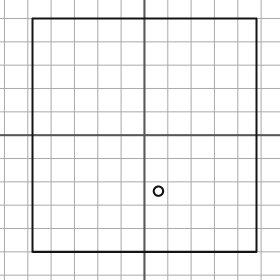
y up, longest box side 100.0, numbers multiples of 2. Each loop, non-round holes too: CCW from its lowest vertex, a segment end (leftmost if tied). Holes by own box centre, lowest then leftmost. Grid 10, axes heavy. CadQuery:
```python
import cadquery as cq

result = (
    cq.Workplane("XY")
    .moveTo(-48.0, -50.0)
    .lineTo(48.0, -50.0)
    .lineTo(48.0, 50.0)
    .lineTo(-48.0, 50.0)
    .close()
    .moveTo(6.0, -24.0)
    .circle(2.0)
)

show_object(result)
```